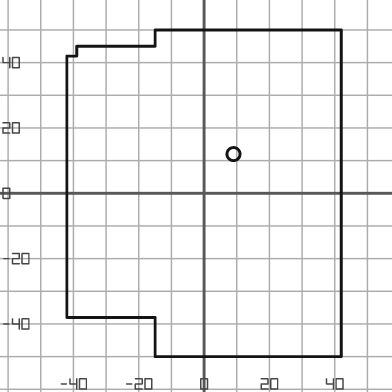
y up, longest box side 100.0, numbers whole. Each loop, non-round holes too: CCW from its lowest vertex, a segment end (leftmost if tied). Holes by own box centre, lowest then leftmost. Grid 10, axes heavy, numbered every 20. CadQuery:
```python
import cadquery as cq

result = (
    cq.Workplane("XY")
    .moveTo(-15.0, -50.0)
    .lineTo(42.0, -50.0)
    .lineTo(42.0, 50.0)
    .lineTo(-15.0, 50.0)
    .lineTo(-15.0, 45.0)
    .lineTo(-39.0, 45.0)
    .lineTo(-39.0, 42.0)
    .lineTo(-42.0, 42.0)
    .lineTo(-42.0, -38.0)
    .lineTo(-15.0, -38.0)
    .close()
    .moveTo(9.0, 12.0)
    .circle(2.0)
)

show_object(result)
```